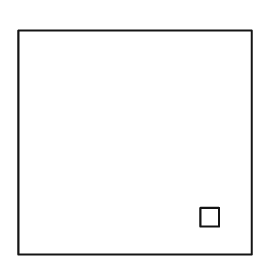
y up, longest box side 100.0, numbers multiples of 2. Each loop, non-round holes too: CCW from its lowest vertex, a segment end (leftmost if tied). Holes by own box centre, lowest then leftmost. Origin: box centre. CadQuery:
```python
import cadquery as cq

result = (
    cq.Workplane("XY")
    .moveTo(-50.0, -48.0)
    .lineTo(50.0, -48.0)
    .lineTo(50.0, 48.0)
    .lineTo(-50.0, 48.0)
    .close()
    .moveTo(28.0, -36.0)
    .lineTo(36.0, -36.0)
    .lineTo(36.0, -28.0)
    .lineTo(28.0, -28.0)
    .close()
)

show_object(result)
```